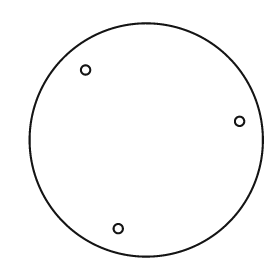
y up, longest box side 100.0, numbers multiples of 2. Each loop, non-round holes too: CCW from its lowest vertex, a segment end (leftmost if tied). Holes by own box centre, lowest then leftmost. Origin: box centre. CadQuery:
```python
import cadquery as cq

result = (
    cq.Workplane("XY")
    .moveTo(0.0, 0.0)
    .circle(50.0)
    .moveTo(-12.0, -38.0)
    .circle(2.0)
    .moveTo(40.0, 8.0)
    .circle(2.0)
    .moveTo(-26.0, 30.0)
    .circle(2.0)
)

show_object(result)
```